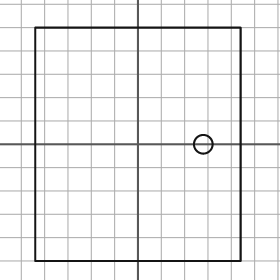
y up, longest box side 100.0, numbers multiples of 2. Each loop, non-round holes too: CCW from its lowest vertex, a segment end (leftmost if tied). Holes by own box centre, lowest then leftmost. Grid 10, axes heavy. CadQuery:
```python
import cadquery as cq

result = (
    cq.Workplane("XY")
    .moveTo(-44.0, -50.0)
    .lineTo(44.0, -50.0)
    .lineTo(44.0, 50.0)
    .lineTo(-44.0, 50.0)
    .close()
    .moveTo(28.0, 0.0)
    .circle(4.0)
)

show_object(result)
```